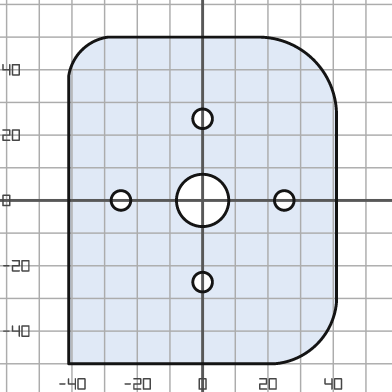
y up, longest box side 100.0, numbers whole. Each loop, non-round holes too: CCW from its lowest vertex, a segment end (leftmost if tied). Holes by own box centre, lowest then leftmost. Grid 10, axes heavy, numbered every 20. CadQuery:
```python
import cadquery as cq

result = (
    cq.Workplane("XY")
    .moveTo(-41.0, -50.0)
    .lineTo(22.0, -50.0)
    .threePointArc((35.0, -44.0), (41.0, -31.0))
    .lineTo(41.0, 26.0)
    .threePointArc((34.0, 43.0), (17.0, 50.0))
    .lineTo(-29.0, 50.0)
    .threePointArc((-37.0, 46.0), (-41.0, 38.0))
    .close()
    .moveTo(0.0, -25.0)
    .circle(3.0)
    .moveTo(-25.0, 0.0)
    .circle(3.0)
    .moveTo(0.0, 0.0)
    .circle(8.0)
    .moveTo(25.0, 0.0)
    .circle(3.0)
    .moveTo(0.0, 25.0)
    .circle(3.0)
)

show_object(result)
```